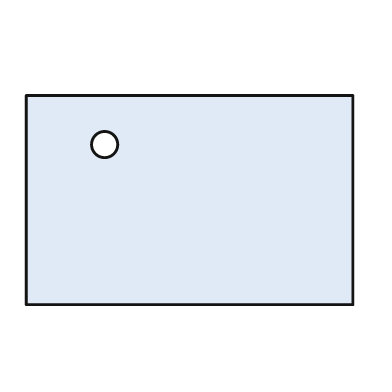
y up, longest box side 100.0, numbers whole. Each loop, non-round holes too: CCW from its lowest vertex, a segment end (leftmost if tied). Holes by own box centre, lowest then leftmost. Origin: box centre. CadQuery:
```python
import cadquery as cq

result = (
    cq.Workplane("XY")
    .moveTo(-50.0, -32.0)
    .lineTo(50.0, -32.0)
    .lineTo(50.0, 32.0)
    .lineTo(-50.0, 32.0)
    .close()
    .moveTo(-26.0, 17.0)
    .circle(4.0)
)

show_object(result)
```